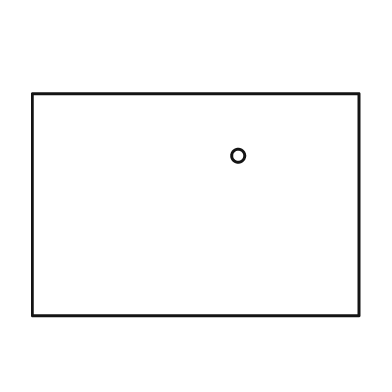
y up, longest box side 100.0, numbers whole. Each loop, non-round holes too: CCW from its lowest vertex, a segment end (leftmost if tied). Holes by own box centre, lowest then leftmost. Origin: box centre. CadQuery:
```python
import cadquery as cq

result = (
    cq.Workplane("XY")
    .moveTo(-50.0, -34.0)
    .lineTo(50.0, -34.0)
    .lineTo(50.0, 34.0)
    .lineTo(-50.0, 34.0)
    .close()
    .moveTo(13.0, 15.0)
    .circle(2.0)
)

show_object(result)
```